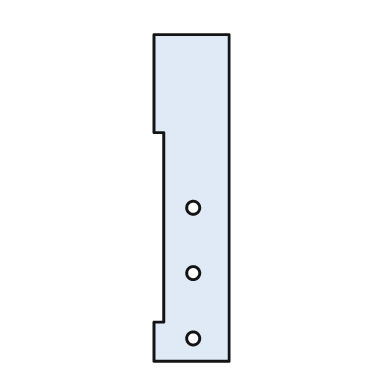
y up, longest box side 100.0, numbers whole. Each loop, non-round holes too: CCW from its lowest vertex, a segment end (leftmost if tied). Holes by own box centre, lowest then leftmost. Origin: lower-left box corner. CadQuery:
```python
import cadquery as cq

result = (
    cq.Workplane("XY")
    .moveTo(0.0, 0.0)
    .lineTo(23.0, 0.0)
    .lineTo(23.0, 100.0)
    .lineTo(0.0, 100.0)
    .lineTo(0.0, 70.0)
    .lineTo(3.0, 70.0)
    .lineTo(3.0, 12.0)
    .lineTo(0.0, 12.0)
    .close()
    .moveTo(12.0, 7.0)
    .circle(2.0)
    .moveTo(12.0, 27.0)
    .circle(2.0)
    .moveTo(12.0, 47.0)
    .circle(2.0)
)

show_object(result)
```